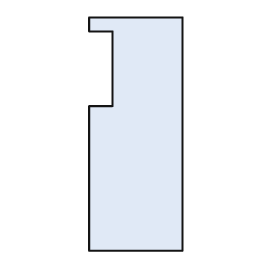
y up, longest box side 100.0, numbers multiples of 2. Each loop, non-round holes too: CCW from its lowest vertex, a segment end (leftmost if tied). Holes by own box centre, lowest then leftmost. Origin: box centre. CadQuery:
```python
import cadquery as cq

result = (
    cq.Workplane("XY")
    .moveTo(-20.0, -50.0)
    .lineTo(20.0, -50.0)
    .lineTo(20.0, 50.0)
    .lineTo(-20.0, 50.0)
    .lineTo(-20.0, 44.0)
    .lineTo(-10.0, 44.0)
    .lineTo(-10.0, 12.0)
    .lineTo(-20.0, 12.0)
    .close()
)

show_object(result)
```